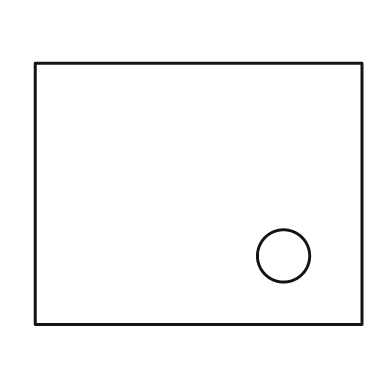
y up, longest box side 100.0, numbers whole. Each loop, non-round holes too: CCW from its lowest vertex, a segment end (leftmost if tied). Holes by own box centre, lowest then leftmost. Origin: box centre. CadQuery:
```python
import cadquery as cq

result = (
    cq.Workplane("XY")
    .moveTo(-50.0, -40.0)
    .lineTo(50.0, -40.0)
    .lineTo(50.0, 40.0)
    .lineTo(-50.0, 40.0)
    .close()
    .moveTo(26.0, -19.0)
    .circle(8.0)
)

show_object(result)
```